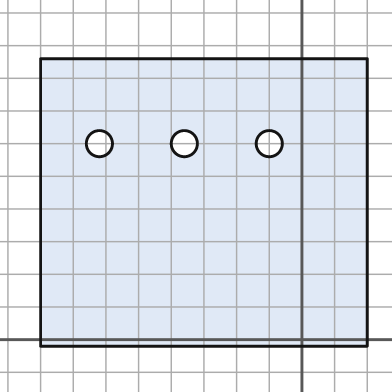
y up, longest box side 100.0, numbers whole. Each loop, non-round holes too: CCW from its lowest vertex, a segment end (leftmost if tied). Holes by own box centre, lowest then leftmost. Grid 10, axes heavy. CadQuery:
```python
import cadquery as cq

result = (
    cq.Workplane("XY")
    .moveTo(-80.0, -2.0)
    .lineTo(20.0, -2.0)
    .lineTo(20.0, 86.0)
    .lineTo(-80.0, 86.0)
    .close()
    .moveTo(-62.0, 60.0)
    .circle(4.0)
    .moveTo(-36.0, 60.0)
    .circle(4.0)
    .moveTo(-10.0, 60.0)
    .circle(4.0)
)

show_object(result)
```